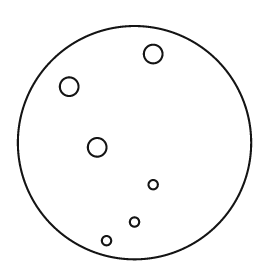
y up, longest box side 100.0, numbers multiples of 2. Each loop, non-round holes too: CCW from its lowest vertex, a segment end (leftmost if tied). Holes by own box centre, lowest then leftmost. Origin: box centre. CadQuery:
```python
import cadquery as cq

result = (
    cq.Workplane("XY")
    .moveTo(0.0, 0.0)
    .circle(50.0)
    .moveTo(-12.0, -42.0)
    .circle(2.0)
    .moveTo(0.0, -34.0)
    .circle(2.0)
    .moveTo(8.0, -18.0)
    .circle(2.0)
    .moveTo(-16.0, -2.0)
    .circle(4.0)
    .moveTo(-28.0, 24.0)
    .circle(4.0)
    .moveTo(8.0, 38.0)
    .circle(4.0)
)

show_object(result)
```